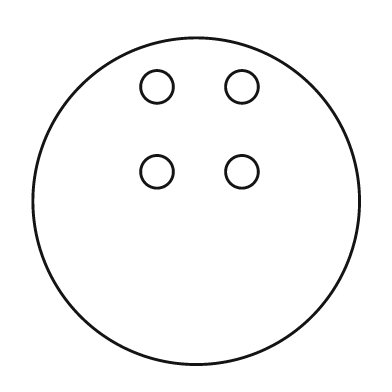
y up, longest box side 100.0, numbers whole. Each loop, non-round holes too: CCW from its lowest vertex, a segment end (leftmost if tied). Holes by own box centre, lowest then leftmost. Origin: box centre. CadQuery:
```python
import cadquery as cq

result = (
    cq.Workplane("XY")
    .moveTo(0.0, 0.0)
    .circle(50.0)
    .moveTo(-12.0, 9.0)
    .circle(5.0)
    .moveTo(14.0, 9.0)
    .circle(5.0)
    .moveTo(-12.0, 35.0)
    .circle(5.0)
    .moveTo(14.0, 35.0)
    .circle(5.0)
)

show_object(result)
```